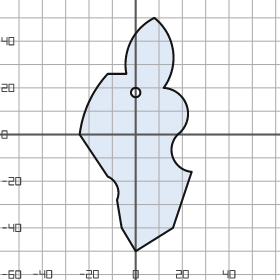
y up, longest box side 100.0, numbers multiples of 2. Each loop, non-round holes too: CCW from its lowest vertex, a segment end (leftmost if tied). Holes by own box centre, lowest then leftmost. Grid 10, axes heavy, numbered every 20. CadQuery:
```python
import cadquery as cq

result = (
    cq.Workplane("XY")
    .moveTo(0.0, -50.0)
    .lineTo(16.0, -40.0)
    .lineTo(24.0, -16.0)
    .threePointArc((16.0, -10.0), (18.0, 0.0))
    .threePointArc((22.0, 12.0), (12.0, 20.0))
    .threePointArc((16.0, 36.0), (8.0, 50.0))
    .threePointArc((-2.0, 40.0), (-4.0, 26.0))
    .lineTo(-12.0, 26.0)
    .threePointArc((-20.0, 14.0), (-24.0, 0.0))
    .lineTo(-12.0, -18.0)
    .threePointArc((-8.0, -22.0), (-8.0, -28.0))
    .lineTo(-6.0, -40.0)
    .close()
    .moveTo(0.0, 18.0)
    .circle(2.0)
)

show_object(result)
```